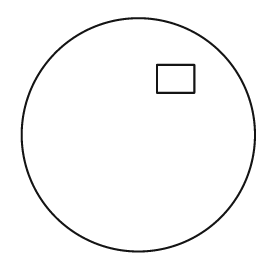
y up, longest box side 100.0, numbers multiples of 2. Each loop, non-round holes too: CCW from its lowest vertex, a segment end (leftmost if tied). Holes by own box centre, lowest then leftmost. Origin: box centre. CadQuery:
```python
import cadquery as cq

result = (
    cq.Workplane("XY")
    .moveTo(0.0, 0.0)
    .circle(50.0)
    .moveTo(8.0, 18.0)
    .lineTo(24.0, 18.0)
    .lineTo(24.0, 30.0)
    .lineTo(8.0, 30.0)
    .close()
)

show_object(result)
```